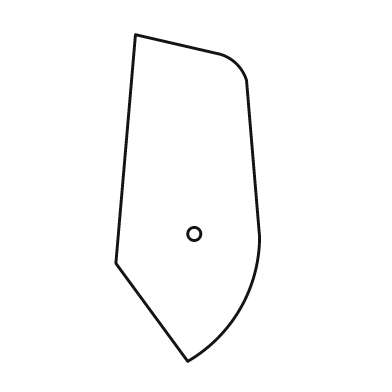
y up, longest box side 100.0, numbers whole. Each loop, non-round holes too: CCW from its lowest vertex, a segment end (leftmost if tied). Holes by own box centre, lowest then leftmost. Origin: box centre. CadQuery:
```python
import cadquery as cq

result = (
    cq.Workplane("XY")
    .moveTo(0.0, -50.0)
    .threePointArc((16.0, -34.0), (22.0, -12.0))
    .lineTo(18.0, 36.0)
    .threePointArc((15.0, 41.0), (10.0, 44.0))
    .lineTo(-16.0, 50.0)
    .lineTo(-22.0, -20.0)
    .close()
    .moveTo(2.0, -11.0)
    .circle(2.0)
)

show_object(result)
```